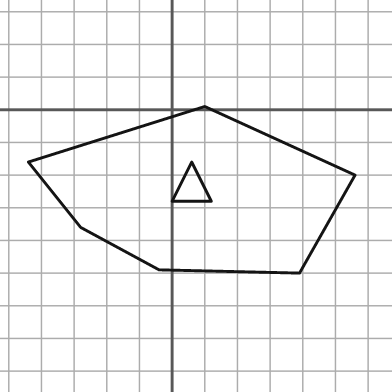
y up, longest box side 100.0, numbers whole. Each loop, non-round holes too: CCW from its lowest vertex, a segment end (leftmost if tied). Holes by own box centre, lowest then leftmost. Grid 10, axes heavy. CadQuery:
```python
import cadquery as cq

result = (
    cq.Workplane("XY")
    .moveTo(39.0, -50.0)
    .lineTo(56.0, -20.0)
    .lineTo(10.0, 1.0)
    .lineTo(-44.0, -16.0)
    .lineTo(-28.0, -36.0)
    .lineTo(-4.0, -49.0)
    .close()
    .moveTo(0.0, -28.0)
    .lineTo(12.0, -28.0)
    .lineTo(6.0, -16.0)
    .close()
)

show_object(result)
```